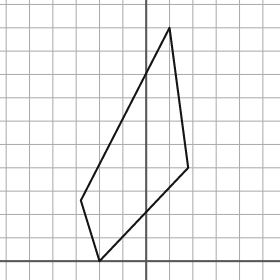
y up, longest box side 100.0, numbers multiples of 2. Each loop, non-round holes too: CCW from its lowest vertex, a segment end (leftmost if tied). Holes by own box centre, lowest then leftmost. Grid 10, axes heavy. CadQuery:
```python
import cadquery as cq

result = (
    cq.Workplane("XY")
    .moveTo(-20.0, 0.0)
    .lineTo(18.0, 40.0)
    .lineTo(10.0, 100.0)
    .lineTo(-28.0, 26.0)
    .close()
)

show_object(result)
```